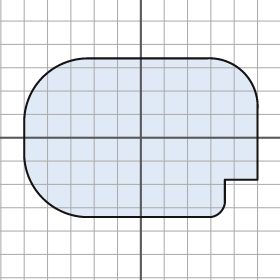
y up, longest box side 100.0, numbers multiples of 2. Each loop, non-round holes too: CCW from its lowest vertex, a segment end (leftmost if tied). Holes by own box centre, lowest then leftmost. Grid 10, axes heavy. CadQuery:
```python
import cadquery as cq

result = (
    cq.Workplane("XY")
    .moveTo(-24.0, -34.0)
    .lineTo(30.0, -34.0)
    .threePointArc((34.0, -32.0), (36.0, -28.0))
    .lineTo(36.0, -18.0)
    .lineTo(50.0, -18.0)
    .lineTo(50.0, 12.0)
    .threePointArc((44.0, 28.0), (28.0, 34.0))
    .lineTo(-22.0, 34.0)
    .threePointArc((-42.0, 26.0), (-50.0, 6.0))
    .lineTo(-50.0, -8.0)
    .threePointArc((-42.0, -26.0), (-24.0, -34.0))
    .close()
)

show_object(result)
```